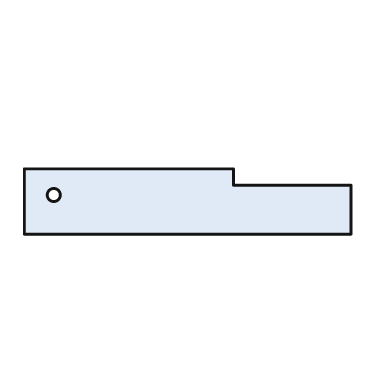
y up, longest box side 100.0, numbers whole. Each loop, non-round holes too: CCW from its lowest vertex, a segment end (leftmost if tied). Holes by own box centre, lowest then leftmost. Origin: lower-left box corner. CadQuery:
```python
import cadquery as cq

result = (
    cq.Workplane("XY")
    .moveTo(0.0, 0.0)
    .lineTo(100.0, 0.0)
    .lineTo(100.0, 15.0)
    .lineTo(64.0, 15.0)
    .lineTo(64.0, 20.0)
    .lineTo(0.0, 20.0)
    .close()
    .moveTo(9.0, 12.0)
    .circle(2.0)
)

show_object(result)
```